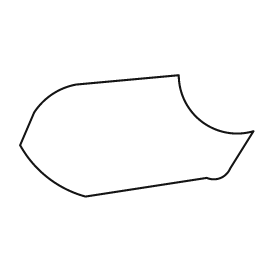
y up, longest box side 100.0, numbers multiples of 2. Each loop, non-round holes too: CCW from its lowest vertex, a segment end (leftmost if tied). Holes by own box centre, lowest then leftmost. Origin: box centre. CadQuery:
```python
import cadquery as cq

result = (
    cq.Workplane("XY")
    .moveTo(-22.0, -26.0)
    .lineTo(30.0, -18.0)
    .threePointArc((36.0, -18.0), (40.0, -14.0))
    .lineTo(50.0, 2.0)
    .threePointArc((28.0, 6.0), (18.0, 26.0))
    .lineTo(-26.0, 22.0)
    .threePointArc((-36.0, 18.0), (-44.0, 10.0))
    .lineTo(-50.0, -4.0)
    .threePointArc((-38.0, -18.0), (-22.0, -26.0))
    .close()
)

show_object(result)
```